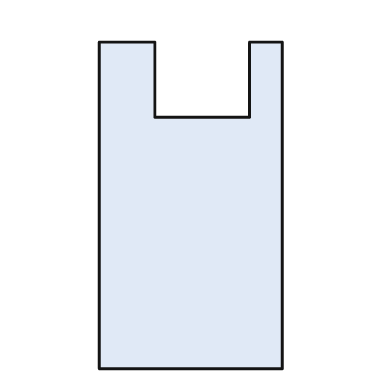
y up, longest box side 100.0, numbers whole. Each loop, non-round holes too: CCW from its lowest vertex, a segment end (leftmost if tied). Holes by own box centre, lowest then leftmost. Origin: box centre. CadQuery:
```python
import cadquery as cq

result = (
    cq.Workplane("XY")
    .moveTo(-28.0, -50.0)
    .lineTo(28.0, -50.0)
    .lineTo(28.0, 50.0)
    .lineTo(18.0, 50.0)
    .lineTo(18.0, 27.0)
    .lineTo(-11.0, 27.0)
    .lineTo(-11.0, 50.0)
    .lineTo(-28.0, 50.0)
    .close()
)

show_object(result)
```